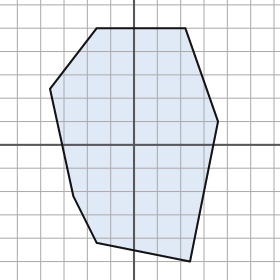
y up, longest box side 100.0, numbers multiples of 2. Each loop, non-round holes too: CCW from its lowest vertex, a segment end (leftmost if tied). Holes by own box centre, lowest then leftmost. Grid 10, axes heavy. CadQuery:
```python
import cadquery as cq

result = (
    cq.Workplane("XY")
    .moveTo(24.0, -50.0)
    .lineTo(36.0, 10.0)
    .lineTo(22.0, 50.0)
    .lineTo(-16.0, 50.0)
    .lineTo(-36.0, 24.0)
    .lineTo(-26.0, -22.0)
    .lineTo(-16.0, -42.0)
    .close()
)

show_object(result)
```